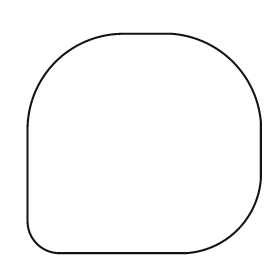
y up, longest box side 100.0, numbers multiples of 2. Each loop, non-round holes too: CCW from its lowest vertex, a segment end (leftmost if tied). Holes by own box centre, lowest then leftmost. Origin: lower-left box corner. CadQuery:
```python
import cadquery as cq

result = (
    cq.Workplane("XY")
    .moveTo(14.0, 0.0)
    .lineTo(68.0, 0.0)
    .threePointArc((90.0, 10.0), (100.0, 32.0))
    .lineTo(100.0, 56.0)
    .threePointArc((88.0, 82.0), (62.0, 94.0))
    .lineTo(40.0, 94.0)
    .threePointArc((12.0, 82.0), (0.0, 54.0))
    .lineTo(0.0, 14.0)
    .threePointArc((4.0, 4.0), (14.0, 0.0))
    .close()
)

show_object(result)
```